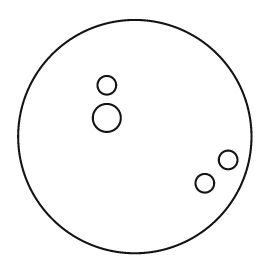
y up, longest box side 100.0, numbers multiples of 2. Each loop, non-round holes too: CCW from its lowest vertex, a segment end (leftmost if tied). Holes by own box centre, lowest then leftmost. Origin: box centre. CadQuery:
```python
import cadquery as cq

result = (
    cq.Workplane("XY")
    .moveTo(0.0, 0.0)
    .circle(50.0)
    .moveTo(30.0, -20.0)
    .circle(4.0)
    .moveTo(40.0, -10.0)
    .circle(4.0)
    .moveTo(-12.0, 8.0)
    .circle(6.0)
    .moveTo(-12.0, 22.0)
    .circle(4.0)
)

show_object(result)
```